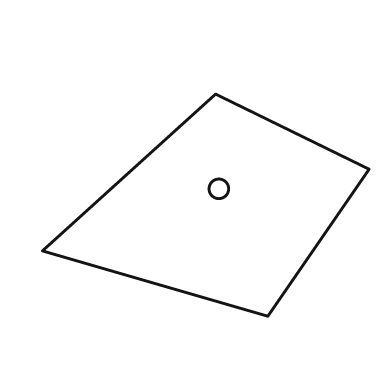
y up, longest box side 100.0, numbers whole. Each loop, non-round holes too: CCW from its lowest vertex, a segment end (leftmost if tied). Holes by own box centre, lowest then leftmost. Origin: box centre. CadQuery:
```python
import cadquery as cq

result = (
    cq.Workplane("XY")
    .moveTo(19.0, -34.0)
    .lineTo(50.0, 11.0)
    .lineTo(3.0, 34.0)
    .lineTo(-50.0, -14.0)
    .close()
    .moveTo(4.0, 5.0)
    .circle(3.0)
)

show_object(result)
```